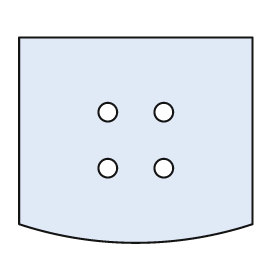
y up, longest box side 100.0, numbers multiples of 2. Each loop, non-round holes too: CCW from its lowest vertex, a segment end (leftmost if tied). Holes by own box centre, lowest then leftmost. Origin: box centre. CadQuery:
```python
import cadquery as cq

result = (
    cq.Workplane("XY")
    .moveTo(-50.0, -36.0)
    .threePointArc((0.0, -44.0), (50.0, -36.0))
    .lineTo(50.0, 44.0)
    .lineTo(-50.0, 44.0)
    .close()
    .moveTo(-12.0, -12.0)
    .circle(4.0)
    .moveTo(12.0, -12.0)
    .circle(4.0)
    .moveTo(-12.0, 12.0)
    .circle(4.0)
    .moveTo(12.0, 12.0)
    .circle(4.0)
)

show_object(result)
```